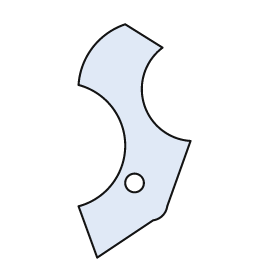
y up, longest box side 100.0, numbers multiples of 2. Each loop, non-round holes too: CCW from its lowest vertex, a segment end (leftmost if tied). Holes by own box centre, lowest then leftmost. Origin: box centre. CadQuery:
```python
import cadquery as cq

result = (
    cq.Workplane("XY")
    .moveTo(-16.0, -50.0)
    .lineTo(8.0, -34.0)
    .threePointArc((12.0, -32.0), (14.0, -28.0))
    .lineTo(24.0, 0.0)
    .threePointArc((4.0, 16.0), (12.0, 40.0))
    .lineTo(-4.0, 50.0)
    .threePointArc((-18.0, 40.0), (-24.0, 24.0))
    .threePointArc((-4.0, -2.0), (-24.0, -28.0))
    .close()
    .moveTo(0.0, -18.0)
    .circle(4.0)
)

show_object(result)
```